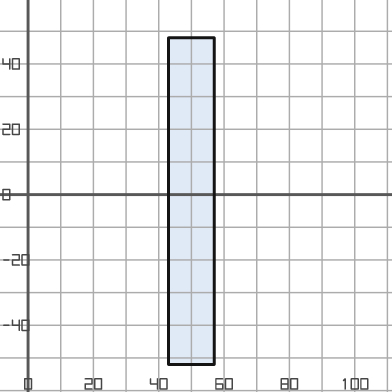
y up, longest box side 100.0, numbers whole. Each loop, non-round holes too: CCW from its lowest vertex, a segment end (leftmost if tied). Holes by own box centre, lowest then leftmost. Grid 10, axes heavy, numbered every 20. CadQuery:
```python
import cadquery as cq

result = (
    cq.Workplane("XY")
    .moveTo(43.0, -52.0)
    .lineTo(57.0, -52.0)
    .lineTo(57.0, 48.0)
    .lineTo(43.0, 48.0)
    .close()
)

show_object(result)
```